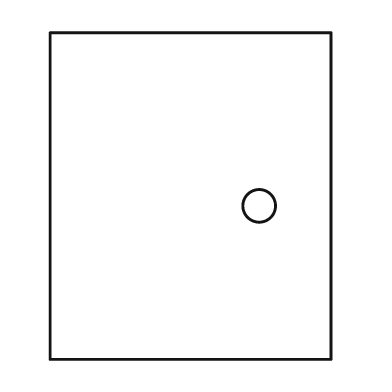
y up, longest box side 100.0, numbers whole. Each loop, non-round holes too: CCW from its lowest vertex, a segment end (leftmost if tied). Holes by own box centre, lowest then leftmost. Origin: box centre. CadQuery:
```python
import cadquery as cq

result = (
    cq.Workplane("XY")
    .moveTo(-43.0, -50.0)
    .lineTo(43.0, -50.0)
    .lineTo(43.0, 50.0)
    .lineTo(-43.0, 50.0)
    .close()
    .moveTo(21.0, -3.0)
    .circle(5.0)
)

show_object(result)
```